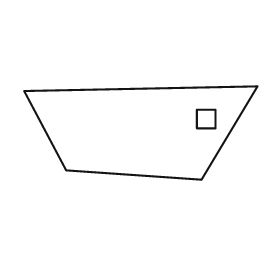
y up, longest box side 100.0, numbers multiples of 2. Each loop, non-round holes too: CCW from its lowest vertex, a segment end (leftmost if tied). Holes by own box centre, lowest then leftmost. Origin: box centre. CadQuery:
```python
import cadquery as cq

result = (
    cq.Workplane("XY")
    .moveTo(26.0, -20.0)
    .lineTo(50.0, 20.0)
    .lineTo(-50.0, 18.0)
    .lineTo(-32.0, -16.0)
    .close()
    .moveTo(24.0, 2.0)
    .lineTo(32.0, 2.0)
    .lineTo(32.0, 10.0)
    .lineTo(24.0, 10.0)
    .close()
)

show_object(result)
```